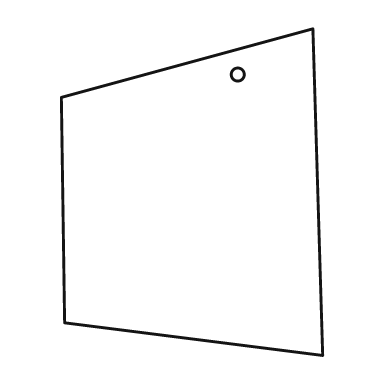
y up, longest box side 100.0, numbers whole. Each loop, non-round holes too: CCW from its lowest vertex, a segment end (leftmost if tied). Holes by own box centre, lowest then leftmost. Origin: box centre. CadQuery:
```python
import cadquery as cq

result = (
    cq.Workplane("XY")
    .moveTo(40.0, -50.0)
    .lineTo(37.0, 50.0)
    .lineTo(-40.0, 29.0)
    .lineTo(-39.0, -40.0)
    .close()
    .moveTo(14.0, 36.0)
    .circle(2.0)
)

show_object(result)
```